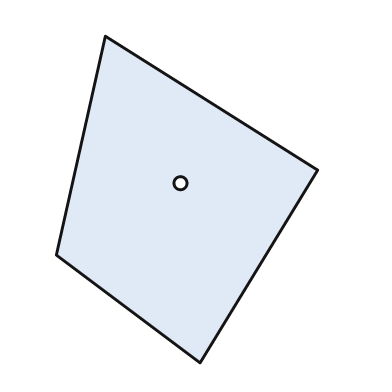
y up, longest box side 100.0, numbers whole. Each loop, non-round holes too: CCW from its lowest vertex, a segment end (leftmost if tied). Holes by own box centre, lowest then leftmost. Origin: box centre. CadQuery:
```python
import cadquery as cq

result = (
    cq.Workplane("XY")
    .moveTo(4.0, -50.0)
    .lineTo(40.0, 9.0)
    .lineTo(-25.0, 50.0)
    .lineTo(-40.0, -17.0)
    .close()
    .moveTo(-2.0, 5.0)
    .circle(2.0)
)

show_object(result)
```